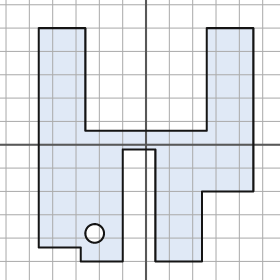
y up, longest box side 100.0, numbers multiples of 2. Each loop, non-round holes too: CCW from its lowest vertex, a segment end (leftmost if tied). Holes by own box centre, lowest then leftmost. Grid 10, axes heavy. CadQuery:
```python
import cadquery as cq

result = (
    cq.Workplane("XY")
    .moveTo(-28.0, -50.0)
    .lineTo(-10.0, -50.0)
    .lineTo(-10.0, -2.0)
    .lineTo(4.0, -2.0)
    .lineTo(4.0, -50.0)
    .lineTo(24.0, -50.0)
    .lineTo(24.0, -20.0)
    .lineTo(46.0, -20.0)
    .lineTo(46.0, 50.0)
    .lineTo(26.0, 50.0)
    .lineTo(26.0, 6.0)
    .lineTo(-26.0, 6.0)
    .lineTo(-26.0, 50.0)
    .lineTo(-46.0, 50.0)
    .lineTo(-46.0, -44.0)
    .lineTo(-28.0, -44.0)
    .close()
    .moveTo(-22.0, -38.0)
    .circle(4.0)
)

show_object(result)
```